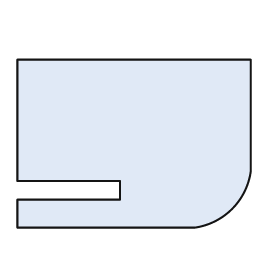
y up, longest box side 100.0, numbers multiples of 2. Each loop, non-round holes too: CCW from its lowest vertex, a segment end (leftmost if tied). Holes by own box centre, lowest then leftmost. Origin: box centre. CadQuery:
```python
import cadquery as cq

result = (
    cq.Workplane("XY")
    .moveTo(-50.0, -36.0)
    .lineTo(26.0, -36.0)
    .threePointArc((42.0, -28.0), (50.0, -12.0))
    .lineTo(50.0, 36.0)
    .lineTo(-50.0, 36.0)
    .lineTo(-50.0, -16.0)
    .lineTo(-6.0, -16.0)
    .lineTo(-6.0, -24.0)
    .lineTo(-50.0, -24.0)
    .close()
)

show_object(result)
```